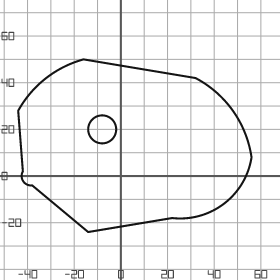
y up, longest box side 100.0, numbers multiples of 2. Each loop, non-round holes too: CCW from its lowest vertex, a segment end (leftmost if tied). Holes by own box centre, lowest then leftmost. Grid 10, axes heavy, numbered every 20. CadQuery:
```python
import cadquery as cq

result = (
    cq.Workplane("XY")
    .moveTo(-14.0, -24.0)
    .lineTo(22.0, -18.0)
    .threePointArc((44.0, -12.0), (56.0, 8.0))
    .threePointArc((48.0, 28.0), (32.0, 42.0))
    .lineTo(-16.0, 50.0)
    .threePointArc((-32.0, 42.0), (-44.0, 28.0))
    .lineTo(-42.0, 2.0)
    .threePointArc((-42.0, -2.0), (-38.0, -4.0))
    .close()
    .moveTo(-8.0, 20.0)
    .circle(6.0)
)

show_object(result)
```